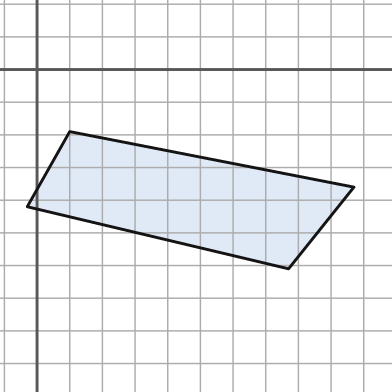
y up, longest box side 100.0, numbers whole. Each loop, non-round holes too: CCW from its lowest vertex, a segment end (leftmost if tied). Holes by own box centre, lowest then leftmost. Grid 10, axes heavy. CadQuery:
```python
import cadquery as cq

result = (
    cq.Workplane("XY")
    .moveTo(77.0, -61.0)
    .lineTo(97.0, -36.0)
    .lineTo(10.0, -19.0)
    .lineTo(-3.0, -42.0)
    .close()
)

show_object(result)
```